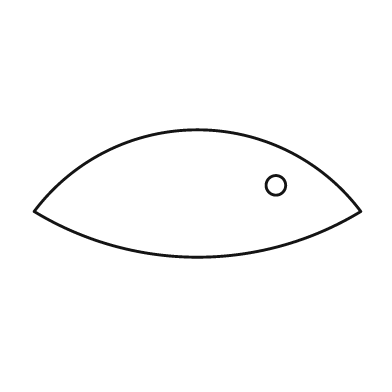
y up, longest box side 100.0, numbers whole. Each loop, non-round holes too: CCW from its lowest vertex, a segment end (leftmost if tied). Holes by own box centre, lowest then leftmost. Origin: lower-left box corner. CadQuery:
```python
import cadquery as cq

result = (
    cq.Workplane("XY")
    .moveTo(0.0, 14.0)
    .threePointArc((50.0, 0.0), (100.0, 14.0))
    .threePointArc((50.0, 39.0), (0.0, 14.0))
    .close()
    .moveTo(74.0, 22.0)
    .circle(3.0)
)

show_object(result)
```